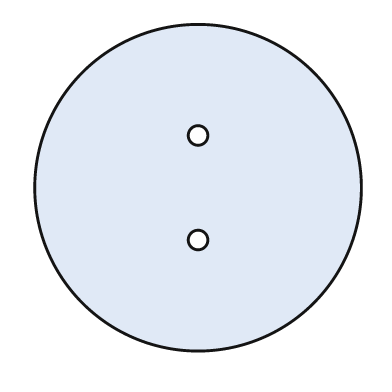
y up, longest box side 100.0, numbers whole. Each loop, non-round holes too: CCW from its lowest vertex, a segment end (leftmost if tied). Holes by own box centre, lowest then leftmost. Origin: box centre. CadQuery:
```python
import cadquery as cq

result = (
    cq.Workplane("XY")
    .moveTo(0.0, 0.0)
    .circle(50.0)
    .moveTo(0.0, -16.0)
    .circle(3.0)
    .moveTo(0.0, 16.0)
    .circle(3.0)
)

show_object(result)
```